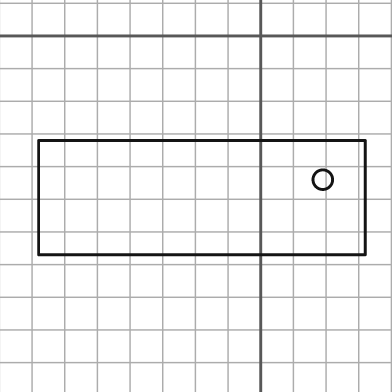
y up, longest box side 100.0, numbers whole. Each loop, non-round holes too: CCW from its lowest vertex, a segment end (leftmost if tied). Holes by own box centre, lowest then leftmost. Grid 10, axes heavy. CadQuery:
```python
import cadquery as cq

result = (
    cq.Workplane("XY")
    .moveTo(-68.0, -67.0)
    .lineTo(32.0, -67.0)
    .lineTo(32.0, -32.0)
    .lineTo(-68.0, -32.0)
    .close()
    .moveTo(19.0, -44.0)
    .circle(3.0)
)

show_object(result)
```